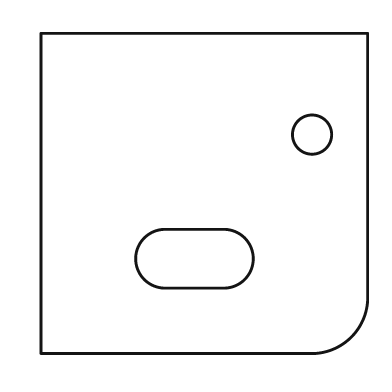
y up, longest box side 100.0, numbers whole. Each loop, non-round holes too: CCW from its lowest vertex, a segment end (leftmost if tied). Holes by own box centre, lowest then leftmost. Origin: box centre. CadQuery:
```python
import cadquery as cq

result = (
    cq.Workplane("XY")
    .moveTo(-50.0, -49.0)
    .lineTo(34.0, -49.0)
    .threePointArc((45.0, -44.0), (50.0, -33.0))
    .lineTo(50.0, 49.0)
    .lineTo(-50.0, 49.0)
    .close()
    .moveTo(-12.0, -29.0)
    .lineTo(6.0, -29.0)
    .threePointArc((15.0, -20.0), (6.0, -11.0))
    .lineTo(-12.0, -11.0)
    .threePointArc((-21.0, -20.0), (-12.0, -29.0))
    .close()
    .moveTo(33.0, 18.0)
    .circle(6.0)
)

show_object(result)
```